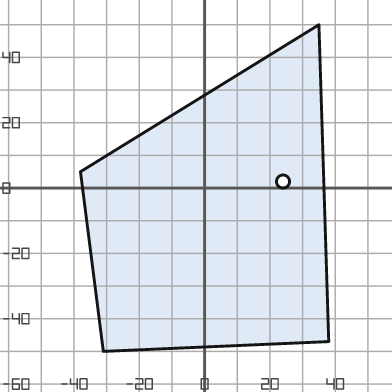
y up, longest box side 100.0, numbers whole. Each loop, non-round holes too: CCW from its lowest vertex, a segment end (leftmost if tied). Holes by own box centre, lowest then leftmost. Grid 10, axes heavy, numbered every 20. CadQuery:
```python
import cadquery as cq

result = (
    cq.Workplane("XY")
    .moveTo(-31.0, -50.0)
    .lineTo(38.0, -47.0)
    .lineTo(35.0, 50.0)
    .lineTo(-38.0, 5.0)
    .close()
    .moveTo(24.0, 2.0)
    .circle(2.0)
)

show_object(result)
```